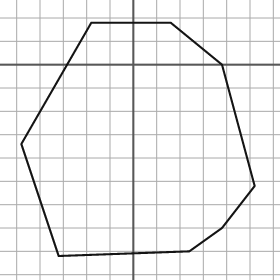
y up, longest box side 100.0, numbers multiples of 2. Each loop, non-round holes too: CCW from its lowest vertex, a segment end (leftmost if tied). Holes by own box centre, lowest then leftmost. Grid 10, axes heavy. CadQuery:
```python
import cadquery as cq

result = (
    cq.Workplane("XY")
    .moveTo(-32.0, -82.0)
    .lineTo(24.0, -80.0)
    .lineTo(38.0, -70.0)
    .lineTo(52.0, -52.0)
    .lineTo(38.0, 0.0)
    .lineTo(16.0, 18.0)
    .lineTo(-18.0, 18.0)
    .lineTo(-48.0, -34.0)
    .close()
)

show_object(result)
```